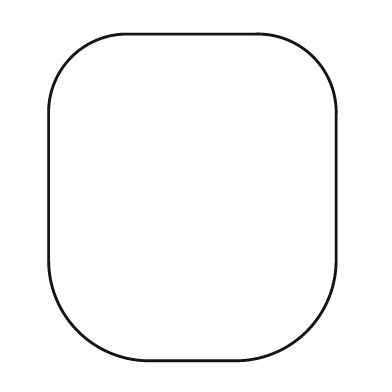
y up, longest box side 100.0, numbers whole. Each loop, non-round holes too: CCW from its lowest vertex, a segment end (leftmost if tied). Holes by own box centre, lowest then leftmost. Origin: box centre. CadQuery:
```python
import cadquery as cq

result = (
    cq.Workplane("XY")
    .moveTo(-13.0, -50.0)
    .lineTo(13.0, -50.0)
    .threePointArc((35.0, -41.0), (44.0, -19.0))
    .lineTo(44.0, 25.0)
    .threePointArc((37.0, 43.0), (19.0, 50.0))
    .lineTo(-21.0, 50.0)
    .threePointArc((-37.0, 43.0), (-44.0, 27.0))
    .lineTo(-44.0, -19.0)
    .threePointArc((-35.0, -41.0), (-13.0, -50.0))
    .close()
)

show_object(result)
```